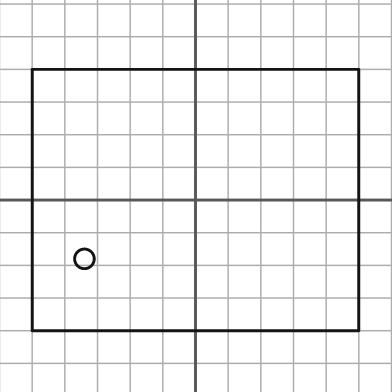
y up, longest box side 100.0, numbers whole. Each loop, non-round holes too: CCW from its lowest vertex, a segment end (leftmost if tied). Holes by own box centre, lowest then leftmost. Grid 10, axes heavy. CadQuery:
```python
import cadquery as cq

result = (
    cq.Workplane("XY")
    .moveTo(-50.0, -40.0)
    .lineTo(50.0, -40.0)
    .lineTo(50.0, 40.0)
    .lineTo(-50.0, 40.0)
    .close()
    .moveTo(-34.0, -18.0)
    .circle(3.0)
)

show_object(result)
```